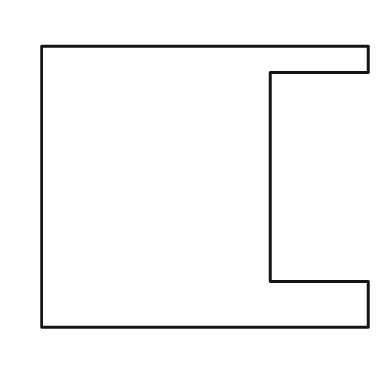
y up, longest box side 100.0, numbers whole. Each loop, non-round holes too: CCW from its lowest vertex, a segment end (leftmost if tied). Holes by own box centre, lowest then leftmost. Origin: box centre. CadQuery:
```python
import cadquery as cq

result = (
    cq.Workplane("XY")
    .moveTo(-50.0, -43.0)
    .lineTo(50.0, -43.0)
    .lineTo(50.0, -29.0)
    .lineTo(20.0, -29.0)
    .lineTo(20.0, 35.0)
    .lineTo(50.0, 35.0)
    .lineTo(50.0, 43.0)
    .lineTo(-50.0, 43.0)
    .close()
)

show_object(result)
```